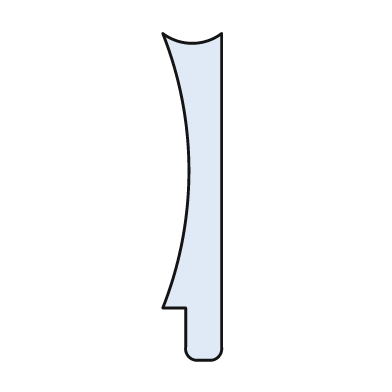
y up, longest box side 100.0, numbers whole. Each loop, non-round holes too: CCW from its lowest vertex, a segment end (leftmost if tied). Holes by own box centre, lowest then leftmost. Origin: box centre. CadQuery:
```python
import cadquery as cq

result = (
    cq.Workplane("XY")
    .moveTo(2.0, -50.0)
    .lineTo(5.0, -50.0)
    .threePointArc((8.0, -49.0), (9.0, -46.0))
    .lineTo(9.0, 50.0)
    .threePointArc((0.0, 47.0), (-9.0, 50.0))
    .threePointArc((-1.0, 8.0), (-9.0, -34.0))
    .lineTo(-2.0, -34.0)
    .lineTo(-2.0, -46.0)
    .threePointArc((-1.0, -49.0), (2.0, -50.0))
    .close()
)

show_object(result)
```